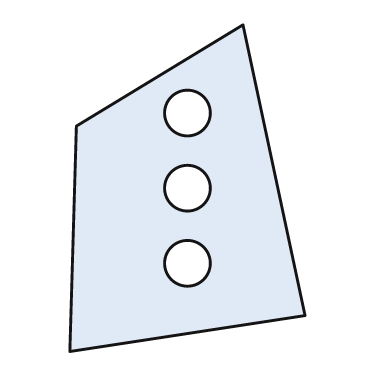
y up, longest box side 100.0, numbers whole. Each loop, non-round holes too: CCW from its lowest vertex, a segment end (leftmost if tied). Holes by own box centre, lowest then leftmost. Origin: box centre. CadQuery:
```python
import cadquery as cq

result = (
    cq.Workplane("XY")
    .moveTo(-36.0, -50.0)
    .lineTo(36.0, -39.0)
    .lineTo(17.0, 50.0)
    .lineTo(-34.0, 19.0)
    .close()
    .moveTo(0.0, -23.0)
    .circle(7.0)
    .moveTo(0.0, 0.0)
    .circle(7.0)
    .moveTo(0.0, 23.0)
    .circle(7.0)
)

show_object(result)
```